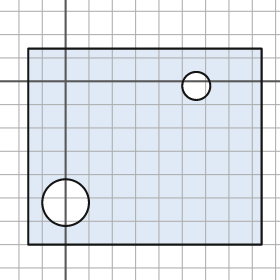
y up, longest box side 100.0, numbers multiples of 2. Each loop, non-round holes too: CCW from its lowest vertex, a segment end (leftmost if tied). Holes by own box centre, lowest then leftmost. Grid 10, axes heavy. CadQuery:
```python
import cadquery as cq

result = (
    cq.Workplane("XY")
    .moveTo(-16.0, -70.0)
    .lineTo(84.0, -70.0)
    .lineTo(84.0, 14.0)
    .lineTo(-16.0, 14.0)
    .close()
    .moveTo(0.0, -52.0)
    .circle(10.0)
    .moveTo(56.0, -2.0)
    .circle(6.0)
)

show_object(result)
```